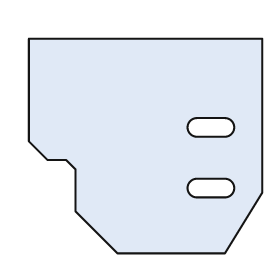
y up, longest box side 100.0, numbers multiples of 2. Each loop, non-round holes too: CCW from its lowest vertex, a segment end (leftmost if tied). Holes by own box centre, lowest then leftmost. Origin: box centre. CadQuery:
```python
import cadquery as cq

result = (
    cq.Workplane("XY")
    .moveTo(-12.0, -46.0)
    .lineTo(34.0, -46.0)
    .lineTo(50.0, -20.0)
    .lineTo(50.0, 46.0)
    .lineTo(-50.0, 46.0)
    .lineTo(-50.0, 2.0)
    .lineTo(-42.0, -6.0)
    .lineTo(-34.0, -6.0)
    .lineTo(-30.0, -10.0)
    .lineTo(-30.0, -28.0)
    .close()
    .moveTo(22.0, -22.0)
    .lineTo(34.0, -22.0)
    .threePointArc((38.0, -18.0), (34.0, -14.0))
    .lineTo(22.0, -14.0)
    .threePointArc((18.0, -18.0), (22.0, -22.0))
    .close()
    .moveTo(22.0, 4.0)
    .lineTo(34.0, 4.0)
    .threePointArc((38.0, 8.0), (34.0, 12.0))
    .lineTo(22.0, 12.0)
    .threePointArc((18.0, 8.0), (22.0, 4.0))
    .close()
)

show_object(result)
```